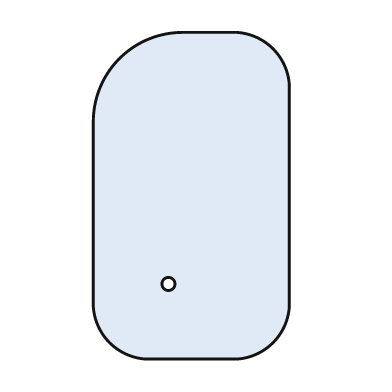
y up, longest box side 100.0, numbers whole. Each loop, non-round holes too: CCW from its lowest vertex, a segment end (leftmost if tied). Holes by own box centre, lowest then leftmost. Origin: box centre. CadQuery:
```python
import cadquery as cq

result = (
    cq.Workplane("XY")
    .moveTo(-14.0, -50.0)
    .lineTo(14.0, -50.0)
    .threePointArc((25.0, -45.0), (30.0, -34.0))
    .lineTo(30.0, 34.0)
    .threePointArc((25.0, 45.0), (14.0, 50.0))
    .lineTo(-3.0, 50.0)
    .threePointArc((-22.0, 42.0), (-30.0, 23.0))
    .lineTo(-30.0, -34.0)
    .threePointArc((-25.0, -45.0), (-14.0, -50.0))
    .close()
    .moveTo(-7.0, -27.0)
    .circle(2.0)
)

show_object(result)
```